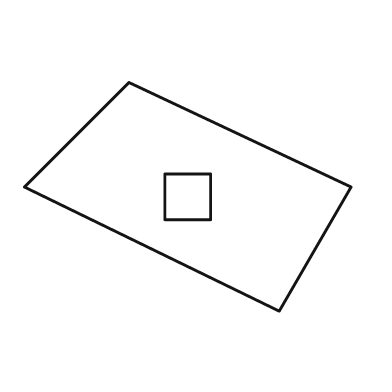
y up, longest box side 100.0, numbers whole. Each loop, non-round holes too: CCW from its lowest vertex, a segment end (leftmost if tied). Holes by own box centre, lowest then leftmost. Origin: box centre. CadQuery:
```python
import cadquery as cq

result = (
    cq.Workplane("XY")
    .moveTo(28.0, -35.0)
    .lineTo(50.0, 3.0)
    .lineTo(-18.0, 35.0)
    .lineTo(-50.0, 3.0)
    .close()
    .moveTo(-7.0, -7.0)
    .lineTo(7.0, -7.0)
    .lineTo(7.0, 7.0)
    .lineTo(-7.0, 7.0)
    .close()
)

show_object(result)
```